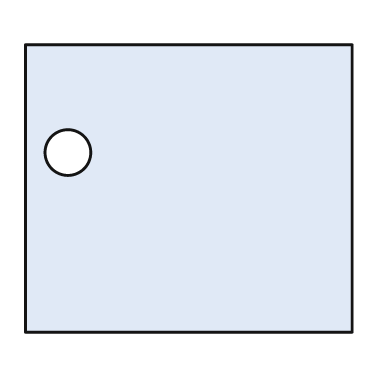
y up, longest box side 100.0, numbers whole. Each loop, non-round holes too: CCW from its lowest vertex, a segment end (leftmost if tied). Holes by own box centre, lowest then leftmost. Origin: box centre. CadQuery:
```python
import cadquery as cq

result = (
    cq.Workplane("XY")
    .moveTo(-50.0, -44.0)
    .lineTo(50.0, -44.0)
    .lineTo(50.0, 44.0)
    .lineTo(-50.0, 44.0)
    .close()
    .moveTo(-37.0, 11.0)
    .circle(7.0)
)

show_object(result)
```